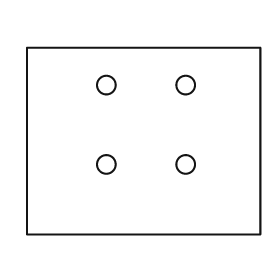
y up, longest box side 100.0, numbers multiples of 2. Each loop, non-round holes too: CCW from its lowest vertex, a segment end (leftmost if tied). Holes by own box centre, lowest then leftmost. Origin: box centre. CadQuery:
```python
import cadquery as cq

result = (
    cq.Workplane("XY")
    .moveTo(-50.0, -40.0)
    .lineTo(50.0, -40.0)
    .lineTo(50.0, 40.0)
    .lineTo(-50.0, 40.0)
    .close()
    .moveTo(-16.0, -10.0)
    .circle(4.0)
    .moveTo(18.0, -10.0)
    .circle(4.0)
    .moveTo(-16.0, 24.0)
    .circle(4.0)
    .moveTo(18.0, 24.0)
    .circle(4.0)
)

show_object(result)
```